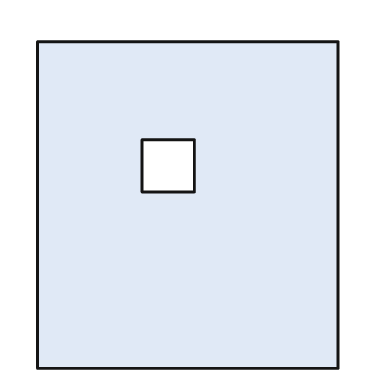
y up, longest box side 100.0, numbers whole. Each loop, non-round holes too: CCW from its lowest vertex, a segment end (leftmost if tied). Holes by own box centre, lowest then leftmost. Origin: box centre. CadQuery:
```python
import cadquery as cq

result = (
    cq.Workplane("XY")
    .moveTo(-46.0, -50.0)
    .lineTo(46.0, -50.0)
    .lineTo(46.0, 50.0)
    .lineTo(-46.0, 50.0)
    .close()
    .moveTo(-14.0, 4.0)
    .lineTo(2.0, 4.0)
    .lineTo(2.0, 20.0)
    .lineTo(-14.0, 20.0)
    .close()
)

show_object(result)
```